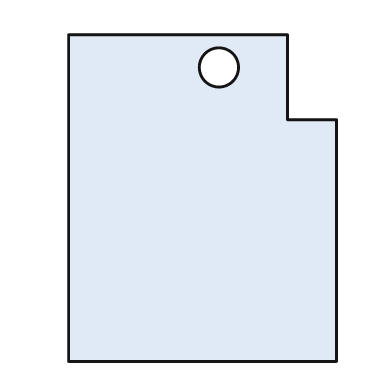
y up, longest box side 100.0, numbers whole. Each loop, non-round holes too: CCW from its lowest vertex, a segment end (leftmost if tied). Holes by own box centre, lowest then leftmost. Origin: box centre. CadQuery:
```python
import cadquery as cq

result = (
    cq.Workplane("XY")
    .moveTo(-41.0, -50.0)
    .lineTo(41.0, -50.0)
    .lineTo(41.0, 24.0)
    .lineTo(26.0, 24.0)
    .lineTo(26.0, 50.0)
    .lineTo(-41.0, 50.0)
    .close()
    .moveTo(5.0, 40.0)
    .circle(6.0)
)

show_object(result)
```